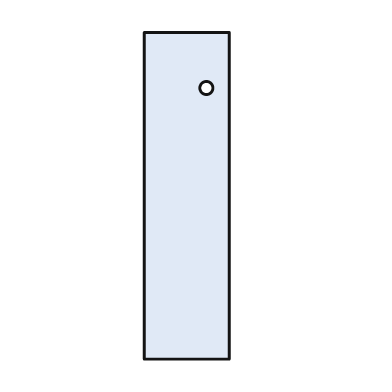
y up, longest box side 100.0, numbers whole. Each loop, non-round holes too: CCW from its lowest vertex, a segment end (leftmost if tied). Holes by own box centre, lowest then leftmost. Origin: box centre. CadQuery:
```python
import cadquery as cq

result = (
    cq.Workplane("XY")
    .moveTo(-13.0, -50.0)
    .lineTo(13.0, -50.0)
    .lineTo(13.0, 50.0)
    .lineTo(-13.0, 50.0)
    .close()
    .moveTo(6.0, 33.0)
    .circle(2.0)
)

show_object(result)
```